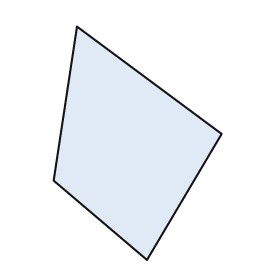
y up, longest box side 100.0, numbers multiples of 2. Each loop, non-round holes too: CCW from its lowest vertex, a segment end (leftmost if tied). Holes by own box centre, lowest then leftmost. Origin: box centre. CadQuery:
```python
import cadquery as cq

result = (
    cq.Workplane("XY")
    .moveTo(4.0, -50.0)
    .lineTo(36.0, 4.0)
    .lineTo(-26.0, 50.0)
    .lineTo(-36.0, -16.0)
    .close()
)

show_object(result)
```